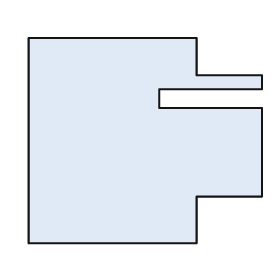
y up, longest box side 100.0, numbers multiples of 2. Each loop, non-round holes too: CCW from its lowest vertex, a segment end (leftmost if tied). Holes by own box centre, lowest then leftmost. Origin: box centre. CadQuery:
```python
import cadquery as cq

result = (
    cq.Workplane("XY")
    .moveTo(-50.0, -44.0)
    .lineTo(22.0, -44.0)
    .lineTo(22.0, -24.0)
    .lineTo(50.0, -24.0)
    .lineTo(50.0, 14.0)
    .lineTo(6.0, 14.0)
    .lineTo(6.0, 22.0)
    .lineTo(50.0, 22.0)
    .lineTo(50.0, 28.0)
    .lineTo(22.0, 28.0)
    .lineTo(22.0, 44.0)
    .lineTo(-50.0, 44.0)
    .close()
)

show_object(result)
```